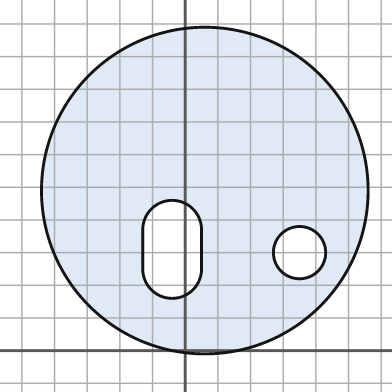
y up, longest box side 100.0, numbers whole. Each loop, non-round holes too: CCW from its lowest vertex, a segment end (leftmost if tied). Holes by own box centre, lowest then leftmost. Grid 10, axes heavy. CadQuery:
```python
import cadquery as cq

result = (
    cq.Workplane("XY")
    .moveTo(6.0, 49.0)
    .circle(50.0)
    .moveTo(35.0, 30.0)
    .circle(8.0)
    .moveTo(-13.0, 25.0)
    .threePointArc((-4.0, 16.0), (5.0, 25.0))
    .lineTo(5.0, 37.0)
    .threePointArc((-4.0, 46.0), (-13.0, 37.0))
    .close()
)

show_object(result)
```